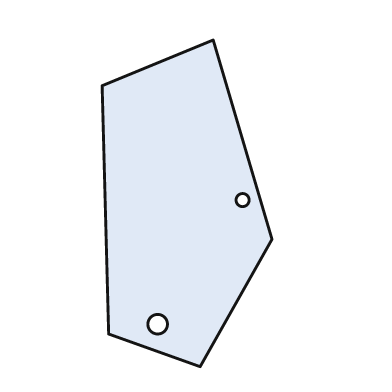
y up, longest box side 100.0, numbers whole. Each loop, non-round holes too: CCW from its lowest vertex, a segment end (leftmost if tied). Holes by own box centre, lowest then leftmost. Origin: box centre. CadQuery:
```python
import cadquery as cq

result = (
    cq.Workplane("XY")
    .moveTo(4.0, -50.0)
    .lineTo(26.0, -11.0)
    .lineTo(8.0, 50.0)
    .lineTo(-26.0, 36.0)
    .lineTo(-24.0, -40.0)
    .close()
    .moveTo(-9.0, -37.0)
    .circle(3.0)
    .moveTo(17.0, 1.0)
    .circle(2.0)
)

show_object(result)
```